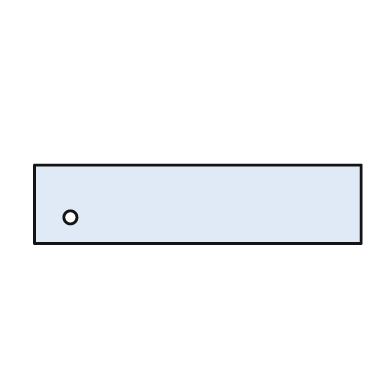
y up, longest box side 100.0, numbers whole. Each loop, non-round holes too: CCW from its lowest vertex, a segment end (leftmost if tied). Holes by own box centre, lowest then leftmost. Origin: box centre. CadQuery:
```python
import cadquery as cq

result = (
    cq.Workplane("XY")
    .moveTo(-50.0, -12.0)
    .lineTo(50.0, -12.0)
    .lineTo(50.0, 12.0)
    .lineTo(-50.0, 12.0)
    .close()
    .moveTo(-39.0, -4.0)
    .circle(2.0)
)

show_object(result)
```